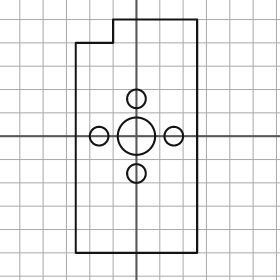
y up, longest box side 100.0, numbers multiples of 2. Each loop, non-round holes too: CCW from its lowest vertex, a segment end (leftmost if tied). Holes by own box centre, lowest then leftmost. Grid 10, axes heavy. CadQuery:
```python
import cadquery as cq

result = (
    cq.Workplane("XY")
    .moveTo(-26.0, -50.0)
    .lineTo(26.0, -50.0)
    .lineTo(26.0, 50.0)
    .lineTo(-10.0, 50.0)
    .lineTo(-10.0, 40.0)
    .lineTo(-26.0, 40.0)
    .close()
    .moveTo(0.0, -16.0)
    .circle(4.0)
    .moveTo(-16.0, 0.0)
    .circle(4.0)
    .moveTo(0.0, 0.0)
    .circle(8.0)
    .moveTo(16.0, 0.0)
    .circle(4.0)
    .moveTo(0.0, 16.0)
    .circle(4.0)
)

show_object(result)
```